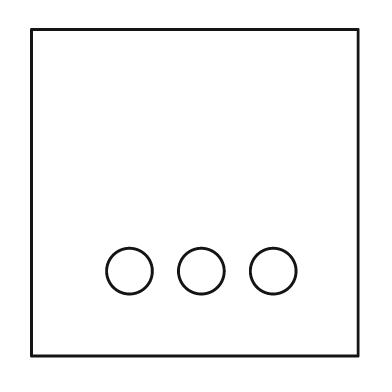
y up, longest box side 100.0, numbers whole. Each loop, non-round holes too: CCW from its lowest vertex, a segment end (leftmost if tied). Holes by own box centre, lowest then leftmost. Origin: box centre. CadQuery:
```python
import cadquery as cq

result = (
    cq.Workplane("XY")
    .moveTo(-50.0, -50.0)
    .lineTo(50.0, -50.0)
    .lineTo(50.0, 50.0)
    .lineTo(-50.0, 50.0)
    .close()
    .moveTo(-20.0, -24.0)
    .circle(7.0)
    .moveTo(2.0, -24.0)
    .circle(7.0)
    .moveTo(24.0, -24.0)
    .circle(7.0)
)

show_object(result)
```